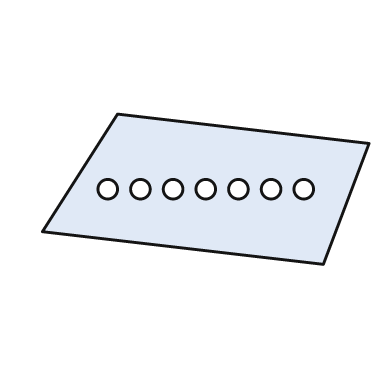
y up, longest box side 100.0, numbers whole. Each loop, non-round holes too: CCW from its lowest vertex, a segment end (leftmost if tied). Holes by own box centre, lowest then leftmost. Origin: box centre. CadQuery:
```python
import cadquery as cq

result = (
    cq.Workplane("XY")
    .moveTo(36.0, -23.0)
    .lineTo(50.0, 14.0)
    .lineTo(-27.0, 23.0)
    .lineTo(-50.0, -13.0)
    .close()
    .moveTo(-30.0, 0.0)
    .circle(3.0)
    .moveTo(-20.0, 0.0)
    .circle(3.0)
    .moveTo(-10.0, 0.0)
    .circle(3.0)
    .moveTo(0.0, 0.0)
    .circle(3.0)
    .moveTo(10.0, 0.0)
    .circle(3.0)
    .moveTo(20.0, 0.0)
    .circle(3.0)
    .moveTo(30.0, 0.0)
    .circle(3.0)
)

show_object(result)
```